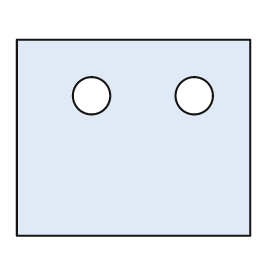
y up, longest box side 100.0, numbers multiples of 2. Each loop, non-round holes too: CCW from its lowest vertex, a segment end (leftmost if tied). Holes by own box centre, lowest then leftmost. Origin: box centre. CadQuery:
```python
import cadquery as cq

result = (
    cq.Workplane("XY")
    .moveTo(-50.0, -42.0)
    .lineTo(50.0, -42.0)
    .lineTo(50.0, 42.0)
    .lineTo(-50.0, 42.0)
    .close()
    .moveTo(-18.0, 18.0)
    .circle(8.0)
    .moveTo(26.0, 18.0)
    .circle(8.0)
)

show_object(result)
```